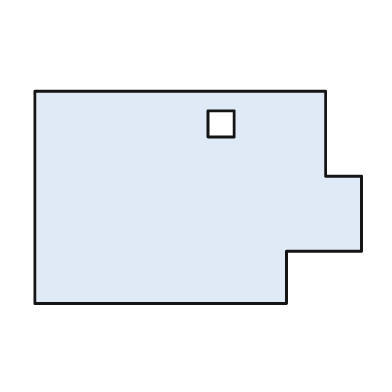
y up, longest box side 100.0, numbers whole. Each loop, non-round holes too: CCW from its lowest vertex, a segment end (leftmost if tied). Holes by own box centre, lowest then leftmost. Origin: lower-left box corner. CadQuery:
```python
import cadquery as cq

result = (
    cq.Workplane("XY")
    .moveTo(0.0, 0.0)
    .lineTo(77.0, 0.0)
    .lineTo(77.0, 16.0)
    .lineTo(100.0, 16.0)
    .lineTo(100.0, 39.0)
    .lineTo(89.0, 39.0)
    .lineTo(89.0, 65.0)
    .lineTo(0.0, 65.0)
    .close()
    .moveTo(53.0, 51.0)
    .lineTo(61.0, 51.0)
    .lineTo(61.0, 59.0)
    .lineTo(53.0, 59.0)
    .close()
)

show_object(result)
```